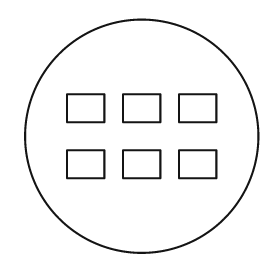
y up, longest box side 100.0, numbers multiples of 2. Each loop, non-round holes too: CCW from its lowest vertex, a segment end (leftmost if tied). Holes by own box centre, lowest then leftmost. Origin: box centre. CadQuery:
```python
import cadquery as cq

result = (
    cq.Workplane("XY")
    .moveTo(0.0, 0.0)
    .circle(50.0)
    .moveTo(-32.0, -18.0)
    .lineTo(-16.0, -18.0)
    .lineTo(-16.0, -6.0)
    .lineTo(-32.0, -6.0)
    .close()
    .moveTo(-8.0, -18.0)
    .lineTo(8.0, -18.0)
    .lineTo(8.0, -6.0)
    .lineTo(-8.0, -6.0)
    .close()
    .moveTo(16.0, -18.0)
    .lineTo(32.0, -18.0)
    .lineTo(32.0, -6.0)
    .lineTo(16.0, -6.0)
    .close()
    .moveTo(-32.0, 6.0)
    .lineTo(-16.0, 6.0)
    .lineTo(-16.0, 18.0)
    .lineTo(-32.0, 18.0)
    .close()
    .moveTo(-8.0, 6.0)
    .lineTo(8.0, 6.0)
    .lineTo(8.0, 18.0)
    .lineTo(-8.0, 18.0)
    .close()
    .moveTo(16.0, 6.0)
    .lineTo(32.0, 6.0)
    .lineTo(32.0, 18.0)
    .lineTo(16.0, 18.0)
    .close()
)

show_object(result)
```